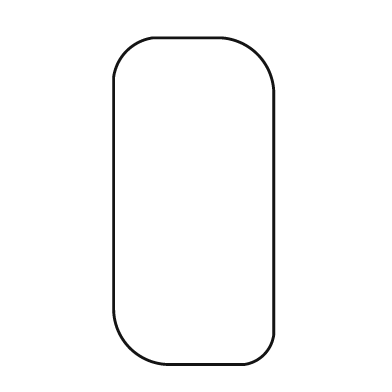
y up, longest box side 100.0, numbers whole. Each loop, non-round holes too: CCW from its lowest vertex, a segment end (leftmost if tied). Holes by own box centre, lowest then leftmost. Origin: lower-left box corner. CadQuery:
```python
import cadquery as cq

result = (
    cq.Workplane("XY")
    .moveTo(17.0, 0.0)
    .lineTo(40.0, 0.0)
    .threePointArc((46.0, 3.0), (49.0, 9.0))
    .lineTo(49.0, 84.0)
    .threePointArc((44.0, 95.0), (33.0, 100.0))
    .lineTo(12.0, 100.0)
    .threePointArc((4.0, 96.0), (0.0, 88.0))
    .lineTo(0.0, 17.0)
    .threePointArc((5.0, 5.0), (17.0, 0.0))
    .close()
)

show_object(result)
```